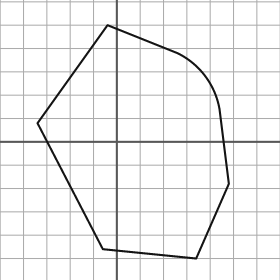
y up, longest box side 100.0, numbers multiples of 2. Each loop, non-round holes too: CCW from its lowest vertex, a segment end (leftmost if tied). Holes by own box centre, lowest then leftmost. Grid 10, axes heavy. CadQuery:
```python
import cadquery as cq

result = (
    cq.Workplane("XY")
    .moveTo(34.0, -50.0)
    .lineTo(48.0, -18.0)
    .lineTo(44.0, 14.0)
    .threePointArc((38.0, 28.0), (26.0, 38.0))
    .lineTo(-4.0, 50.0)
    .lineTo(-34.0, 8.0)
    .lineTo(-6.0, -46.0)
    .close()
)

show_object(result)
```